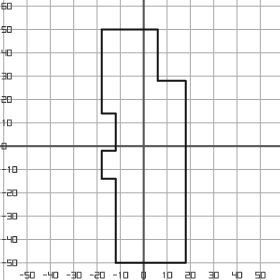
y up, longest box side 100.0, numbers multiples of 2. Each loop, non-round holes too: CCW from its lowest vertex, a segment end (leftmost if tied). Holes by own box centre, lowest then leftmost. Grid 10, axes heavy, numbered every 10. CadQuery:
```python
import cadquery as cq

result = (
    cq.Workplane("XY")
    .moveTo(-12.0, -50.0)
    .lineTo(18.0, -50.0)
    .lineTo(18.0, 28.0)
    .lineTo(6.0, 28.0)
    .lineTo(6.0, 50.0)
    .lineTo(-18.0, 50.0)
    .lineTo(-18.0, 14.0)
    .lineTo(-12.0, 14.0)
    .lineTo(-12.0, -2.0)
    .lineTo(-18.0, -2.0)
    .lineTo(-18.0, -14.0)
    .lineTo(-12.0, -14.0)
    .close()
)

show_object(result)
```